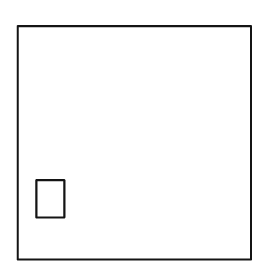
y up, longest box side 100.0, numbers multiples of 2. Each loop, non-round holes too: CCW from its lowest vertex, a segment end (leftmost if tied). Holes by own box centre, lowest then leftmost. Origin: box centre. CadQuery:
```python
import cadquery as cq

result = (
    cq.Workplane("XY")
    .moveTo(-50.0, -50.0)
    .lineTo(50.0, -50.0)
    .lineTo(50.0, 50.0)
    .lineTo(-50.0, 50.0)
    .close()
    .moveTo(-42.0, -32.0)
    .lineTo(-30.0, -32.0)
    .lineTo(-30.0, -16.0)
    .lineTo(-42.0, -16.0)
    .close()
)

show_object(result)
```